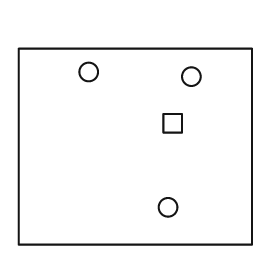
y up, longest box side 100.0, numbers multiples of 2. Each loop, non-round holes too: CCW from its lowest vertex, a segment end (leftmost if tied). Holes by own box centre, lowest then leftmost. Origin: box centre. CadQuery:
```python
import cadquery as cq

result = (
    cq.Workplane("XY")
    .moveTo(-50.0, -42.0)
    .lineTo(50.0, -42.0)
    .lineTo(50.0, 42.0)
    .lineTo(-50.0, 42.0)
    .close()
    .moveTo(14.0, -26.0)
    .circle(4.0)
    .moveTo(12.0, 6.0)
    .lineTo(20.0, 6.0)
    .lineTo(20.0, 14.0)
    .lineTo(12.0, 14.0)
    .close()
    .moveTo(24.0, 30.0)
    .circle(4.0)
    .moveTo(-20.0, 32.0)
    .circle(4.0)
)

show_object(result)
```